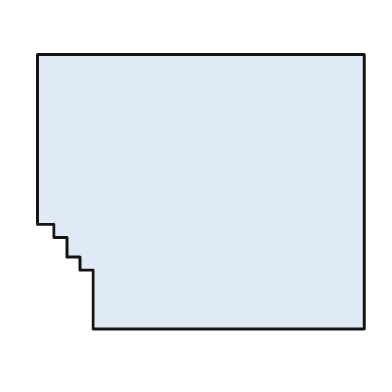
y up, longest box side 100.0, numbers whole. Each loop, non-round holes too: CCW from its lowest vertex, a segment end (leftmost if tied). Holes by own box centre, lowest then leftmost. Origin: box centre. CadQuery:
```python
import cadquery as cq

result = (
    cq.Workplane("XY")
    .moveTo(-33.0, -42.0)
    .lineTo(50.0, -42.0)
    .lineTo(50.0, 42.0)
    .lineTo(-50.0, 42.0)
    .lineTo(-50.0, -10.0)
    .lineTo(-45.0, -10.0)
    .lineTo(-45.0, -14.0)
    .lineTo(-41.0, -14.0)
    .lineTo(-41.0, -20.0)
    .lineTo(-37.0, -20.0)
    .lineTo(-37.0, -24.0)
    .lineTo(-33.0, -24.0)
    .close()
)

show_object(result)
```